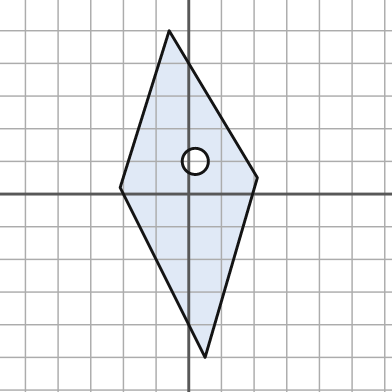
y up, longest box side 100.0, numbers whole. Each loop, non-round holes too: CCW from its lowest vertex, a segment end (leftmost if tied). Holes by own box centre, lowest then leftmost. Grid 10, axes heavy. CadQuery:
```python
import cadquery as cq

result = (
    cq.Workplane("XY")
    .moveTo(5.0, -50.0)
    .lineTo(21.0, 5.0)
    .lineTo(-6.0, 50.0)
    .lineTo(-21.0, 2.0)
    .close()
    .moveTo(2.0, 10.0)
    .circle(4.0)
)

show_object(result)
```